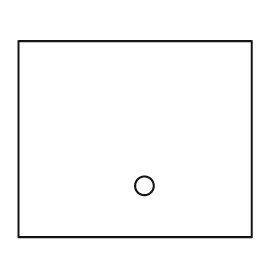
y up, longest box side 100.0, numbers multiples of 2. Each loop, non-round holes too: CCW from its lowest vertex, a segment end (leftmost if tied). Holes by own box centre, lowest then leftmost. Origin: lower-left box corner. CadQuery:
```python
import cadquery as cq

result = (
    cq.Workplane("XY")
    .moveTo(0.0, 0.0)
    .lineTo(100.0, 0.0)
    .lineTo(100.0, 84.0)
    .lineTo(0.0, 84.0)
    .close()
    .moveTo(54.0, 22.0)
    .circle(4.0)
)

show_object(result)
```